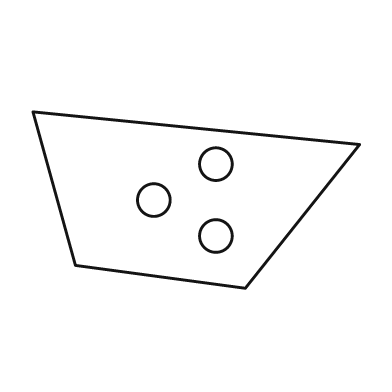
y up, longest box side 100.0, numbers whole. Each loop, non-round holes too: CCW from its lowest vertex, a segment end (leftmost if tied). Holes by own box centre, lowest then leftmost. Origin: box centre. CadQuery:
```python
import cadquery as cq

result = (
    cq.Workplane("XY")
    .moveTo(15.0, -27.0)
    .lineTo(50.0, 17.0)
    .lineTo(-50.0, 27.0)
    .lineTo(-37.0, -20.0)
    .close()
    .moveTo(6.0, -11.0)
    .circle(5.0)
    .moveTo(-13.0, 0.0)
    .circle(5.0)
    .moveTo(6.0, 11.0)
    .circle(5.0)
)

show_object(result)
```